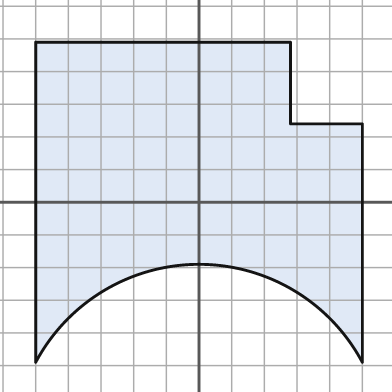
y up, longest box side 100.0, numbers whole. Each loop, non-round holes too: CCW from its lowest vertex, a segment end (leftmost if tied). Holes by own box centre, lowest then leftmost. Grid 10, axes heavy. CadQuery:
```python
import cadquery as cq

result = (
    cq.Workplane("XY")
    .moveTo(-50.0, -49.0)
    .threePointArc((0.0, -19.0), (50.0, -49.0))
    .lineTo(50.0, 24.0)
    .lineTo(28.0, 24.0)
    .lineTo(28.0, 49.0)
    .lineTo(-50.0, 49.0)
    .close()
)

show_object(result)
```